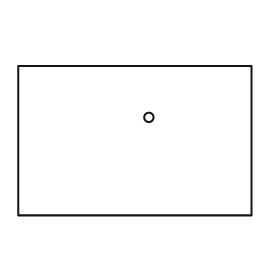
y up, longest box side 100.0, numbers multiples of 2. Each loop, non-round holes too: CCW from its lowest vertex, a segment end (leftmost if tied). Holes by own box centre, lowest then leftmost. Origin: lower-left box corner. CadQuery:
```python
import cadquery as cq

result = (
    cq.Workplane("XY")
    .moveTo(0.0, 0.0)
    .lineTo(100.0, 0.0)
    .lineTo(100.0, 64.0)
    .lineTo(0.0, 64.0)
    .close()
    .moveTo(56.0, 42.0)
    .circle(2.0)
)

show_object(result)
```